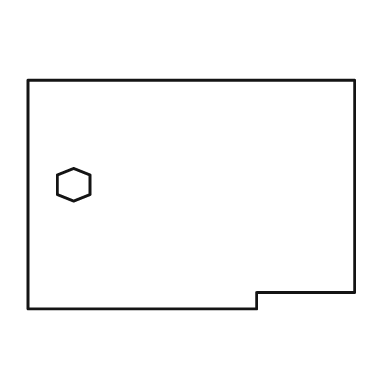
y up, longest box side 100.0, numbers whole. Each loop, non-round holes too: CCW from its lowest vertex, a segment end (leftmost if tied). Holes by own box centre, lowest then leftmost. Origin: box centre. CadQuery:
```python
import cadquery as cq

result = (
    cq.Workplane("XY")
    .moveTo(-50.0, -35.0)
    .lineTo(20.0, -35.0)
    .lineTo(20.0, -30.0)
    .lineTo(50.0, -30.0)
    .lineTo(50.0, 35.0)
    .lineTo(-50.0, 35.0)
    .close()
    .moveTo(-36.0, -2.0)
    .lineTo(-31.0, 0.0)
    .lineTo(-31.0, 6.0)
    .lineTo(-36.0, 8.0)
    .lineTo(-41.0, 6.0)
    .lineTo(-41.0, 0.0)
    .close()
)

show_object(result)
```